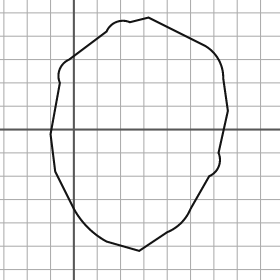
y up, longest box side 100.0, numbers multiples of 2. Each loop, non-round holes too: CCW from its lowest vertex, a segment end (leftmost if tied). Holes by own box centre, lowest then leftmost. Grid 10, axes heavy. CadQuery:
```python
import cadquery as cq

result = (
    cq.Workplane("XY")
    .moveTo(28.0, -52.0)
    .lineTo(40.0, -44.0)
    .threePointArc((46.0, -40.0), (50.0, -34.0))
    .lineTo(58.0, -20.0)
    .threePointArc((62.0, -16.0), (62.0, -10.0))
    .lineTo(66.0, 8.0)
    .lineTo(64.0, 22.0)
    .threePointArc((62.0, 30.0), (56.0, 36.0))
    .lineTo(32.0, 48.0)
    .lineTo(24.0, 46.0)
    .threePointArc((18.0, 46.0), (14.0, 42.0))
    .lineTo(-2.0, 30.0)
    .threePointArc((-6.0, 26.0), (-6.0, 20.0))
    .lineTo(-10.0, -2.0)
    .lineTo(-8.0, -18.0)
    .lineTo(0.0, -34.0)
    .threePointArc((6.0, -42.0), (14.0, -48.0))
    .close()
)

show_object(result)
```